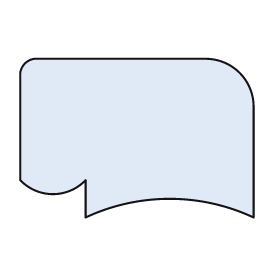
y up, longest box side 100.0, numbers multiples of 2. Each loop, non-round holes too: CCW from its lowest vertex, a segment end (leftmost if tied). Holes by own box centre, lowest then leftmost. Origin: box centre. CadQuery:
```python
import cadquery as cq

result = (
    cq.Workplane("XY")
    .moveTo(-22.0, -34.0)
    .threePointArc((14.0, -26.0), (50.0, -34.0))
    .lineTo(50.0, 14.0)
    .threePointArc((44.0, 28.0), (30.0, 34.0))
    .lineTo(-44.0, 34.0)
    .threePointArc((-48.0, 32.0), (-50.0, 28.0))
    .lineTo(-50.0, -18.0)
    .threePointArc((-36.0, -24.0), (-22.0, -18.0))
    .close()
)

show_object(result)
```